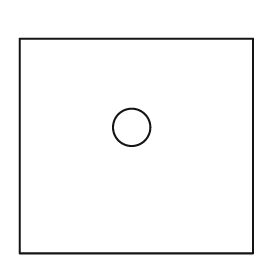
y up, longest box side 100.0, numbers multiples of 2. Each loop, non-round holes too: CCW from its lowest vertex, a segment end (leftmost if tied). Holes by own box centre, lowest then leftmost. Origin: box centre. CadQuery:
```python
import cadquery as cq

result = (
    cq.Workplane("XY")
    .moveTo(-50.0, -46.0)
    .lineTo(50.0, -46.0)
    .lineTo(50.0, 46.0)
    .lineTo(-50.0, 46.0)
    .close()
    .moveTo(-2.0, 8.0)
    .circle(8.0)
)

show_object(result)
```